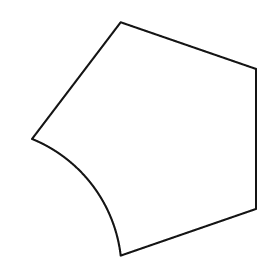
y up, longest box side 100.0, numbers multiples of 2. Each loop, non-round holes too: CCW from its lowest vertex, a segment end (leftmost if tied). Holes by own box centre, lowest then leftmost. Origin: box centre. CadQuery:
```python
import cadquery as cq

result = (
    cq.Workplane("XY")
    .moveTo(-10.0, -50.0)
    .lineTo(48.0, -30.0)
    .lineTo(48.0, 30.0)
    .lineTo(-10.0, 50.0)
    .lineTo(-48.0, 0.0)
    .threePointArc((-22.0, -20.0), (-10.0, -50.0))
    .close()
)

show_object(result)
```